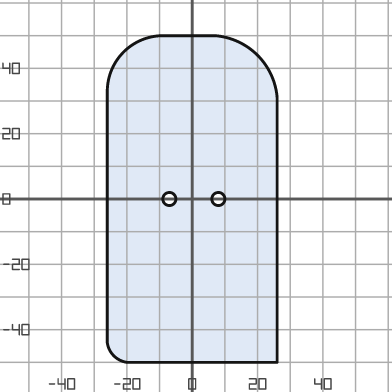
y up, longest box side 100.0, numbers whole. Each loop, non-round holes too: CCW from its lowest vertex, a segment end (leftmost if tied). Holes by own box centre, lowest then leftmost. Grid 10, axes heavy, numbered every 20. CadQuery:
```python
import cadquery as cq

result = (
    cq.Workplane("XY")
    .moveTo(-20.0, -50.0)
    .lineTo(26.0, -50.0)
    .lineTo(26.0, 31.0)
    .threePointArc((20.0, 44.0), (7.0, 50.0))
    .lineTo(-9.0, 50.0)
    .threePointArc((-21.0, 45.0), (-26.0, 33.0))
    .lineTo(-26.0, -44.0)
    .threePointArc((-24.0, -48.0), (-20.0, -50.0))
    .close()
    .moveTo(-7.0, 0.0)
    .circle(2.0)
    .moveTo(8.0, 0.0)
    .circle(2.0)
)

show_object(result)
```